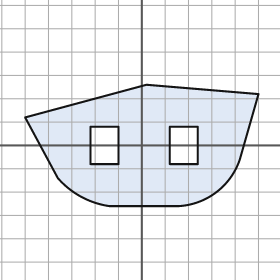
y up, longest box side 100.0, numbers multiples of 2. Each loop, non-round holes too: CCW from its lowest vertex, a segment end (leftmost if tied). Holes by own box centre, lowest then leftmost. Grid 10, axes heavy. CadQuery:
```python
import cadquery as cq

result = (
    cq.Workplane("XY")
    .moveTo(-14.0, -26.0)
    .lineTo(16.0, -26.0)
    .threePointArc((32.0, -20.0), (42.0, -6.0))
    .lineTo(50.0, 22.0)
    .lineTo(2.0, 26.0)
    .lineTo(-50.0, 12.0)
    .lineTo(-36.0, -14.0)
    .threePointArc((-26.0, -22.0), (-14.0, -26.0))
    .close()
    .moveTo(-22.0, -8.0)
    .lineTo(-10.0, -8.0)
    .lineTo(-10.0, 8.0)
    .lineTo(-22.0, 8.0)
    .close()
    .moveTo(12.0, -8.0)
    .lineTo(24.0, -8.0)
    .lineTo(24.0, 8.0)
    .lineTo(12.0, 8.0)
    .close()
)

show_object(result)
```